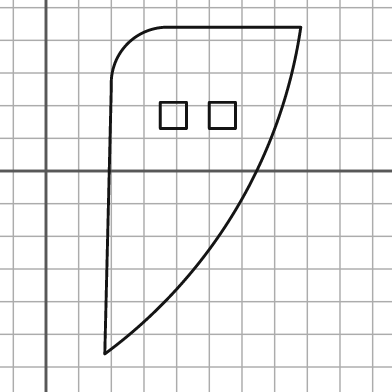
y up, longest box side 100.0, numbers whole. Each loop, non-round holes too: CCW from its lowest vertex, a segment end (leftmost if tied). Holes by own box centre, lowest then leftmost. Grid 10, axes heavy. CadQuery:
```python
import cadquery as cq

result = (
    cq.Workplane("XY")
    .moveTo(18.0, -56.0)
    .threePointArc((58.0, -12.0), (78.0, 44.0))
    .lineTo(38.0, 44.0)
    .threePointArc((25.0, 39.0), (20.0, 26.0))
    .close()
    .moveTo(35.0, 13.0)
    .lineTo(43.0, 13.0)
    .lineTo(43.0, 21.0)
    .lineTo(35.0, 21.0)
    .close()
    .moveTo(50.0, 13.0)
    .lineTo(58.0, 13.0)
    .lineTo(58.0, 21.0)
    .lineTo(50.0, 21.0)
    .close()
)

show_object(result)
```